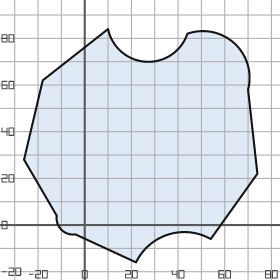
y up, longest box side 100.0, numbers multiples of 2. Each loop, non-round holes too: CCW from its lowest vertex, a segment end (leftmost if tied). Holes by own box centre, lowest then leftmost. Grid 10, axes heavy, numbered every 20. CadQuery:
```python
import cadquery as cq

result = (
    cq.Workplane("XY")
    .moveTo(22.0, -16.0)
    .threePointArc((36.0, -4.0), (54.0, -6.0))
    .lineTo(74.0, 22.0)
    .lineTo(70.0, 58.0)
    .threePointArc((64.0, 78.0), (44.0, 82.0))
    .threePointArc((26.0, 70.0), (10.0, 84.0))
    .lineTo(-18.0, 62.0)
    .lineTo(-26.0, 28.0)
    .lineTo(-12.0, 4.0)
    .threePointArc((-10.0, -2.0), (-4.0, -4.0))
    .close()
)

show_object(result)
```